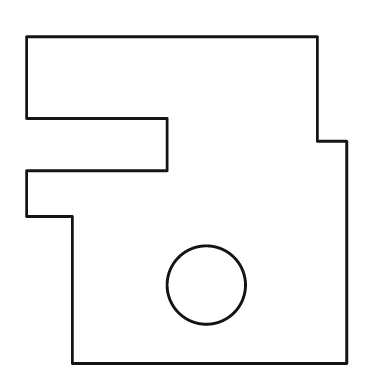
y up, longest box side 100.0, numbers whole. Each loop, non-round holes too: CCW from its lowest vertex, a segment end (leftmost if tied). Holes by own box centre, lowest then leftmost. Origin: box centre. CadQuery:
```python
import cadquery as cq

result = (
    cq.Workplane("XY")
    .moveTo(-35.0, -50.0)
    .lineTo(49.0, -50.0)
    .lineTo(49.0, 18.0)
    .lineTo(40.0, 18.0)
    .lineTo(40.0, 50.0)
    .lineTo(-49.0, 50.0)
    .lineTo(-49.0, 25.0)
    .lineTo(-6.0, 25.0)
    .lineTo(-6.0, 9.0)
    .lineTo(-49.0, 9.0)
    .lineTo(-49.0, -5.0)
    .lineTo(-35.0, -5.0)
    .close()
    .moveTo(6.0, -26.0)
    .circle(12.0)
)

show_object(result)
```